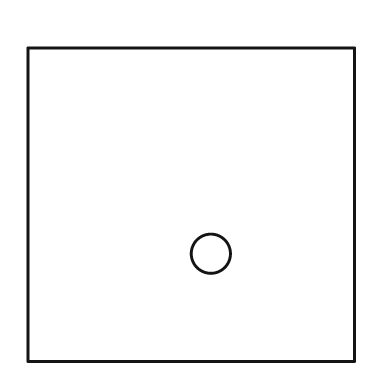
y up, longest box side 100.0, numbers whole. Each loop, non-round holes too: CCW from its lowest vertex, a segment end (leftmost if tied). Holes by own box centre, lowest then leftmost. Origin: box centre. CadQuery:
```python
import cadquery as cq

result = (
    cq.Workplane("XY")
    .moveTo(-50.0, -48.0)
    .lineTo(50.0, -48.0)
    .lineTo(50.0, 48.0)
    .lineTo(-50.0, 48.0)
    .close()
    .moveTo(6.0, -15.0)
    .circle(6.0)
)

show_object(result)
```